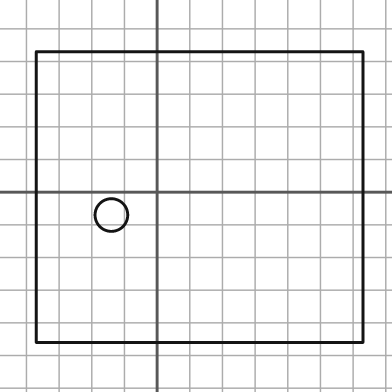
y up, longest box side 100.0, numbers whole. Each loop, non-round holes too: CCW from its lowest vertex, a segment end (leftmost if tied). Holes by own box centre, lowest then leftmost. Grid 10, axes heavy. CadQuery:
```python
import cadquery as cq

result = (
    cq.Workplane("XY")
    .moveTo(-37.0, -46.0)
    .lineTo(63.0, -46.0)
    .lineTo(63.0, 43.0)
    .lineTo(-37.0, 43.0)
    .close()
    .moveTo(-14.0, -7.0)
    .circle(5.0)
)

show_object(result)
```